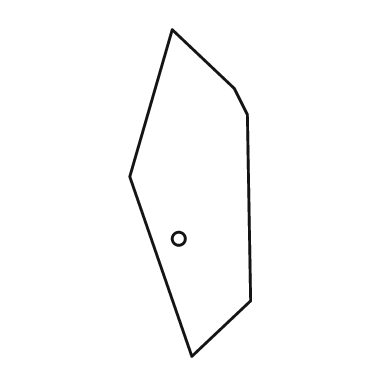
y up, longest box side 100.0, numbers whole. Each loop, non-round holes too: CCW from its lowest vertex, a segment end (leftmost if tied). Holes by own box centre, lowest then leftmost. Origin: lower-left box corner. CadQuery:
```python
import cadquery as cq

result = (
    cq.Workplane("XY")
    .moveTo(19.0, 0.0)
    .lineTo(37.0, 17.0)
    .lineTo(36.0, 74.0)
    .lineTo(32.0, 82.0)
    .lineTo(13.0, 100.0)
    .lineTo(0.0, 55.0)
    .close()
    .moveTo(15.0, 36.0)
    .circle(2.0)
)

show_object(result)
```